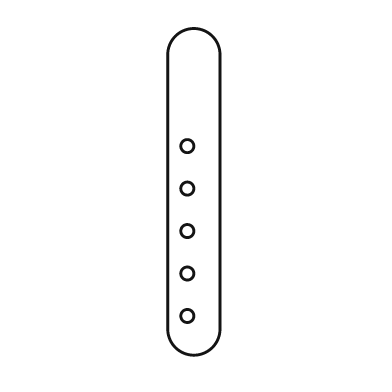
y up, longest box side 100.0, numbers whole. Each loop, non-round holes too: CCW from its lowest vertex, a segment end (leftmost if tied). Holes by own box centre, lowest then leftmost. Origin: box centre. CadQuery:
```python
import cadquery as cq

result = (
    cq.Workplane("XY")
    .moveTo(-8.0, -42.0)
    .threePointArc((0.0, -50.0), (8.0, -42.0))
    .lineTo(8.0, 42.0)
    .threePointArc((0.0, 50.0), (-8.0, 42.0))
    .close()
    .moveTo(-2.0, -38.0)
    .circle(2.0)
    .moveTo(-2.0, -25.0)
    .circle(2.0)
    .moveTo(-2.0, -12.0)
    .circle(2.0)
    .moveTo(-2.0, 1.0)
    .circle(2.0)
    .moveTo(-2.0, 14.0)
    .circle(2.0)
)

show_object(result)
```